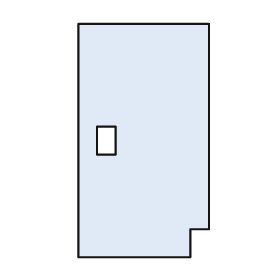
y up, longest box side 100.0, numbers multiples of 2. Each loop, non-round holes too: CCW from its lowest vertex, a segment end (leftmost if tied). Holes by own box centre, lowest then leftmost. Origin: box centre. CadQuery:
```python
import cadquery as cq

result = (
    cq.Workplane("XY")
    .moveTo(-28.0, -50.0)
    .lineTo(20.0, -50.0)
    .lineTo(20.0, -38.0)
    .lineTo(28.0, -38.0)
    .lineTo(28.0, 50.0)
    .lineTo(-28.0, 50.0)
    .close()
    .moveTo(-20.0, -6.0)
    .lineTo(-12.0, -6.0)
    .lineTo(-12.0, 6.0)
    .lineTo(-20.0, 6.0)
    .close()
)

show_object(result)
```